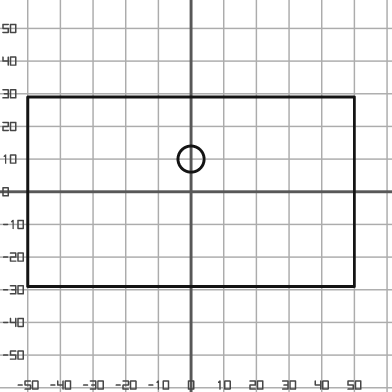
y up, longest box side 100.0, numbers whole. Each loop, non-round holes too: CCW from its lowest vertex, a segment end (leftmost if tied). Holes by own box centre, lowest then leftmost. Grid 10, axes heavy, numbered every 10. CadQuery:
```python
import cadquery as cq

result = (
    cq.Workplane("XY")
    .moveTo(-50.0, -29.0)
    .lineTo(50.0, -29.0)
    .lineTo(50.0, 29.0)
    .lineTo(-50.0, 29.0)
    .close()
    .moveTo(0.0, 10.0)
    .circle(4.0)
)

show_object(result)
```